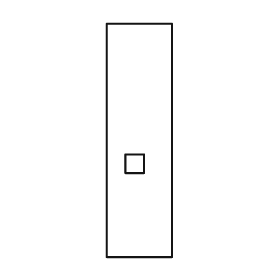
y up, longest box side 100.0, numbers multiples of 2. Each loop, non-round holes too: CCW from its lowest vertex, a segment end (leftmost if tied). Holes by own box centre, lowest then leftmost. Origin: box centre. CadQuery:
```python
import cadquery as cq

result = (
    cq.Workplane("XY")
    .moveTo(-14.0, -50.0)
    .lineTo(14.0, -50.0)
    .lineTo(14.0, 50.0)
    .lineTo(-14.0, 50.0)
    .close()
    .moveTo(-6.0, -14.0)
    .lineTo(2.0, -14.0)
    .lineTo(2.0, -6.0)
    .lineTo(-6.0, -6.0)
    .close()
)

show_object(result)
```